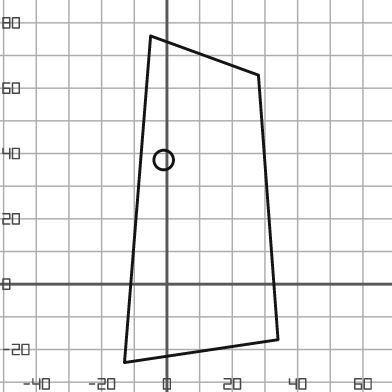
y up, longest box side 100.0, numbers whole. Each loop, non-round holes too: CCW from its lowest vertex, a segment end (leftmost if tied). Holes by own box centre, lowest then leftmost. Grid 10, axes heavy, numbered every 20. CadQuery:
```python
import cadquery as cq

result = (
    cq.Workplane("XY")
    .moveTo(-13.0, -24.0)
    .lineTo(34.0, -17.0)
    .lineTo(28.0, 64.0)
    .lineTo(-5.0, 76.0)
    .close()
    .moveTo(-1.0, 38.0)
    .circle(3.0)
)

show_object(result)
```